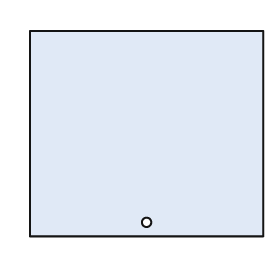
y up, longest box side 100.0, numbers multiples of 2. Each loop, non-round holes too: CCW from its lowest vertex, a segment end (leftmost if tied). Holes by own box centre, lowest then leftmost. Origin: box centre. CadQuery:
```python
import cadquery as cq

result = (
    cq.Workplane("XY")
    .moveTo(-50.0, -44.0)
    .lineTo(50.0, -44.0)
    .lineTo(50.0, 44.0)
    .lineTo(-50.0, 44.0)
    .close()
    .moveTo(0.0, -38.0)
    .circle(2.0)
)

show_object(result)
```